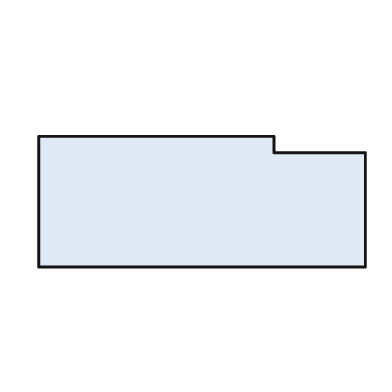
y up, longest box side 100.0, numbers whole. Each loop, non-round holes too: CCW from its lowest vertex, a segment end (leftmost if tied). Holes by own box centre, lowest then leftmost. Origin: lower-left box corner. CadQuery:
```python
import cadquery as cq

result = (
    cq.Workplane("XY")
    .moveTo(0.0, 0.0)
    .lineTo(100.0, 0.0)
    .lineTo(100.0, 35.0)
    .lineTo(72.0, 35.0)
    .lineTo(72.0, 40.0)
    .lineTo(0.0, 40.0)
    .close()
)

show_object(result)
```